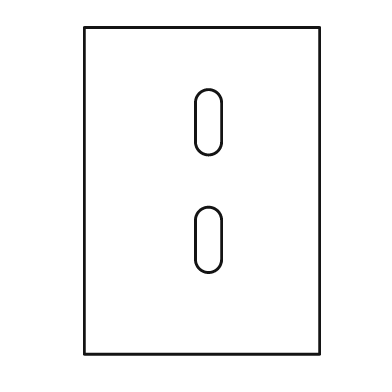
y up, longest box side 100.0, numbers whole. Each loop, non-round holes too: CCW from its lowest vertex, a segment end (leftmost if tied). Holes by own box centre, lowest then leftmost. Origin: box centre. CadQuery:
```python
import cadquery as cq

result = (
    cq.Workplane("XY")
    .moveTo(-36.0, -50.0)
    .lineTo(36.0, -50.0)
    .lineTo(36.0, 50.0)
    .lineTo(-36.0, 50.0)
    .close()
    .moveTo(-2.0, -21.0)
    .threePointArc((2.0, -25.0), (6.0, -21.0))
    .lineTo(6.0, -9.0)
    .threePointArc((2.0, -5.0), (-2.0, -9.0))
    .close()
    .moveTo(-2.0, 15.0)
    .threePointArc((2.0, 11.0), (6.0, 15.0))
    .lineTo(6.0, 27.0)
    .threePointArc((2.0, 31.0), (-2.0, 27.0))
    .close()
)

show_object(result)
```